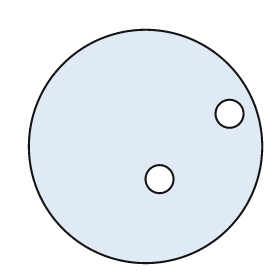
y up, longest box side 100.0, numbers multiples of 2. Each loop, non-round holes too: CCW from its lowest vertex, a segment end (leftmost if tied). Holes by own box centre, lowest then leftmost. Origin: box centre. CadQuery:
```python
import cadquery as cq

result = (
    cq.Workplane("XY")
    .moveTo(0.0, 0.0)
    .circle(50.0)
    .moveTo(6.0, -14.0)
    .circle(6.0)
    .moveTo(36.0, 14.0)
    .circle(6.0)
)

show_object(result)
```